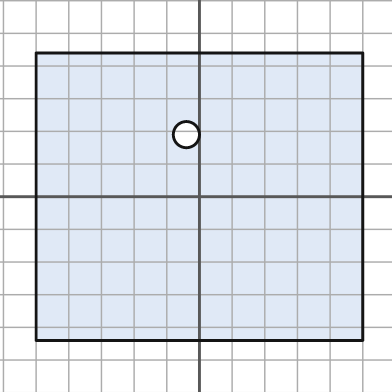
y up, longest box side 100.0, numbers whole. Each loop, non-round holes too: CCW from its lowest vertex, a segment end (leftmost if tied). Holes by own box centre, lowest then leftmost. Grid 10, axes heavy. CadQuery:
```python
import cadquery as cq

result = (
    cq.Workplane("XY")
    .moveTo(-50.0, -44.0)
    .lineTo(50.0, -44.0)
    .lineTo(50.0, 44.0)
    .lineTo(-50.0, 44.0)
    .close()
    .moveTo(-4.0, 19.0)
    .circle(4.0)
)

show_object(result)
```